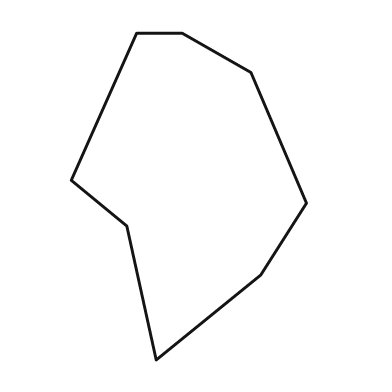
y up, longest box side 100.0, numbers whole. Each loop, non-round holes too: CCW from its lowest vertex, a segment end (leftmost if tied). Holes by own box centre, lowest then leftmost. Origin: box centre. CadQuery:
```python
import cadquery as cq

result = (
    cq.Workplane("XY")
    .moveTo(-10.0, -50.0)
    .lineTo(22.0, -24.0)
    .lineTo(36.0, -2.0)
    .lineTo(19.0, 38.0)
    .lineTo(-2.0, 50.0)
    .lineTo(-16.0, 50.0)
    .lineTo(-36.0, 5.0)
    .lineTo(-19.0, -9.0)
    .close()
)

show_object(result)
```